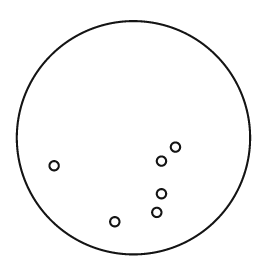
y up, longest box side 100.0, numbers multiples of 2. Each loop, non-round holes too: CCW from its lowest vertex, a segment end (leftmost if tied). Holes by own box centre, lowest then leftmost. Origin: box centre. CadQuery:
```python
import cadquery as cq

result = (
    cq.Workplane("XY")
    .moveTo(0.0, 0.0)
    .circle(50.0)
    .moveTo(-8.0, -36.0)
    .circle(2.0)
    .moveTo(10.0, -32.0)
    .circle(2.0)
    .moveTo(12.0, -24.0)
    .circle(2.0)
    .moveTo(-34.0, -12.0)
    .circle(2.0)
    .moveTo(12.0, -10.0)
    .circle(2.0)
    .moveTo(18.0, -4.0)
    .circle(2.0)
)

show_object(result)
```